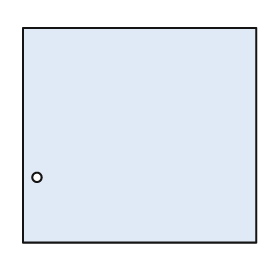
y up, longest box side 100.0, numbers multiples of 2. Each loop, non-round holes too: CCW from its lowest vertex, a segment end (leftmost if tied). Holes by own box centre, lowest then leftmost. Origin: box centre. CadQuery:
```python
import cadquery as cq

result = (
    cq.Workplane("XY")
    .moveTo(-50.0, -46.0)
    .lineTo(50.0, -46.0)
    .lineTo(50.0, 46.0)
    .lineTo(-50.0, 46.0)
    .close()
    .moveTo(-44.0, -18.0)
    .circle(2.0)
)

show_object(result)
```